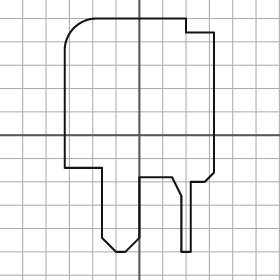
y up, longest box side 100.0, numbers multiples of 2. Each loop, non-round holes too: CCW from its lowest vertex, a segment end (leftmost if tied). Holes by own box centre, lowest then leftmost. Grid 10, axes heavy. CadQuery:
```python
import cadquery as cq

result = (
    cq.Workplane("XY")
    .moveTo(-10.0, -50.0)
    .lineTo(-6.0, -50.0)
    .lineTo(0.0, -44.0)
    .lineTo(0.0, -18.0)
    .lineTo(14.0, -18.0)
    .lineTo(18.0, -26.0)
    .lineTo(18.0, -50.0)
    .lineTo(22.0, -50.0)
    .lineTo(22.0, -20.0)
    .lineTo(28.0, -20.0)
    .lineTo(32.0, -16.0)
    .lineTo(32.0, 44.0)
    .lineTo(20.0, 44.0)
    .lineTo(20.0, 50.0)
    .lineTo(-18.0, 50.0)
    .threePointArc((-28.0, 46.0), (-32.0, 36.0))
    .lineTo(-32.0, -14.0)
    .lineTo(-16.0, -14.0)
    .lineTo(-16.0, -44.0)
    .close()
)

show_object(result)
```